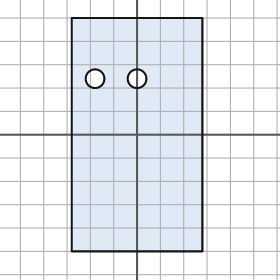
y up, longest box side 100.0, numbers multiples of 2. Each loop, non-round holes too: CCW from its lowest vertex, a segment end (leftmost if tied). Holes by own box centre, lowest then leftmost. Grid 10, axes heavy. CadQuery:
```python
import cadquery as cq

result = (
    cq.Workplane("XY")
    .moveTo(-28.0, -50.0)
    .lineTo(28.0, -50.0)
    .lineTo(28.0, 50.0)
    .lineTo(-28.0, 50.0)
    .close()
    .moveTo(-18.0, 24.0)
    .circle(4.0)
    .moveTo(0.0, 24.0)
    .circle(4.0)
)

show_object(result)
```